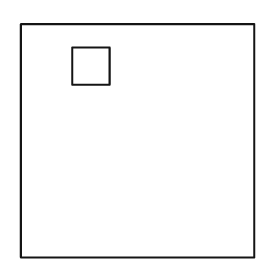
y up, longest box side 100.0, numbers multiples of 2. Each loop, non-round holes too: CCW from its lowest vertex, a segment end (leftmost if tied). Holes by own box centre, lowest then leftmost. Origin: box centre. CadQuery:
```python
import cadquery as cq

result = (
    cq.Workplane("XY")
    .moveTo(-50.0, -50.0)
    .lineTo(50.0, -50.0)
    .lineTo(50.0, 50.0)
    .lineTo(-50.0, 50.0)
    .close()
    .moveTo(-28.0, 24.0)
    .lineTo(-12.0, 24.0)
    .lineTo(-12.0, 40.0)
    .lineTo(-28.0, 40.0)
    .close()
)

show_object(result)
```